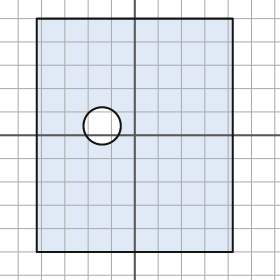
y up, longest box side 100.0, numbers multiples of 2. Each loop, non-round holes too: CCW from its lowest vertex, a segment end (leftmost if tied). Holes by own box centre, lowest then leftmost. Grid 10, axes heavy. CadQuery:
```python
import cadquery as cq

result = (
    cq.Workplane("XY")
    .moveTo(-42.0, -50.0)
    .lineTo(42.0, -50.0)
    .lineTo(42.0, 50.0)
    .lineTo(-42.0, 50.0)
    .close()
    .moveTo(-14.0, 4.0)
    .circle(8.0)
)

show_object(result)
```